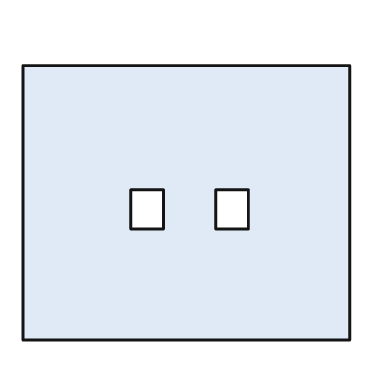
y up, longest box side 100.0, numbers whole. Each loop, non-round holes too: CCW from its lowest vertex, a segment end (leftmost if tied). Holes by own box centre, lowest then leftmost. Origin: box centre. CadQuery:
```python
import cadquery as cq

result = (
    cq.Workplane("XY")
    .moveTo(-50.0, -42.0)
    .lineTo(50.0, -42.0)
    .lineTo(50.0, 42.0)
    .lineTo(-50.0, 42.0)
    .close()
    .moveTo(-17.0, -8.0)
    .lineTo(-7.0, -8.0)
    .lineTo(-7.0, 4.0)
    .lineTo(-17.0, 4.0)
    .close()
    .moveTo(9.0, -8.0)
    .lineTo(19.0, -8.0)
    .lineTo(19.0, 4.0)
    .lineTo(9.0, 4.0)
    .close()
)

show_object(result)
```